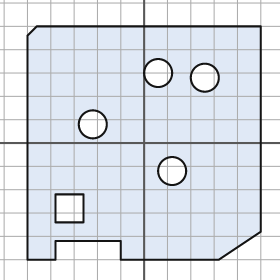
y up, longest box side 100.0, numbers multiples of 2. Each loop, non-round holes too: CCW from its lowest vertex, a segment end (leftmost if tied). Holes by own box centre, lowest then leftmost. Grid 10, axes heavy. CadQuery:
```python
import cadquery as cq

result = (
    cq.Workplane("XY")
    .moveTo(-50.0, -50.0)
    .lineTo(-38.0, -50.0)
    .lineTo(-38.0, -42.0)
    .lineTo(-10.0, -42.0)
    .lineTo(-10.0, -50.0)
    .lineTo(32.0, -50.0)
    .lineTo(50.0, -38.0)
    .lineTo(50.0, 50.0)
    .lineTo(-46.0, 50.0)
    .lineTo(-50.0, 46.0)
    .close()
    .moveTo(-38.0, -34.0)
    .lineTo(-26.0, -34.0)
    .lineTo(-26.0, -22.0)
    .lineTo(-38.0, -22.0)
    .close()
    .moveTo(12.0, -12.0)
    .circle(6.0)
    .moveTo(-22.0, 8.0)
    .circle(6.0)
    .moveTo(26.0, 28.0)
    .circle(6.0)
    .moveTo(6.0, 30.0)
    .circle(6.0)
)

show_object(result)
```